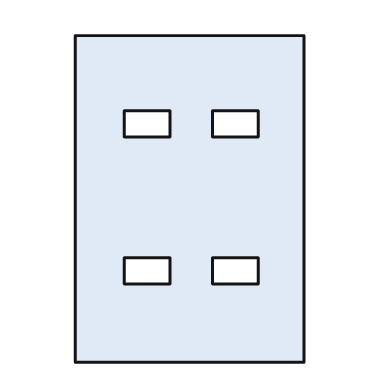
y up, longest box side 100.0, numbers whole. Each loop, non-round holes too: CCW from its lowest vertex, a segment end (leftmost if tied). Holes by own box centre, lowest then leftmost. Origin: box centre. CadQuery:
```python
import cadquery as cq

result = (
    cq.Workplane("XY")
    .moveTo(-35.0, -50.0)
    .lineTo(35.0, -50.0)
    .lineTo(35.0, 50.0)
    .lineTo(-35.0, 50.0)
    .close()
    .moveTo(-20.0, -26.0)
    .lineTo(-6.0, -26.0)
    .lineTo(-6.0, -18.0)
    .lineTo(-20.0, -18.0)
    .close()
    .moveTo(7.0, -26.0)
    .lineTo(21.0, -26.0)
    .lineTo(21.0, -18.0)
    .lineTo(7.0, -18.0)
    .close()
    .moveTo(-20.0, 19.0)
    .lineTo(-6.0, 19.0)
    .lineTo(-6.0, 27.0)
    .lineTo(-20.0, 27.0)
    .close()
    .moveTo(7.0, 19.0)
    .lineTo(21.0, 19.0)
    .lineTo(21.0, 27.0)
    .lineTo(7.0, 27.0)
    .close()
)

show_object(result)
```